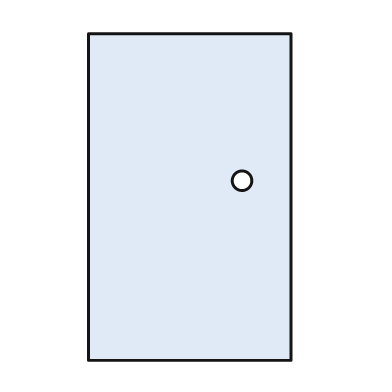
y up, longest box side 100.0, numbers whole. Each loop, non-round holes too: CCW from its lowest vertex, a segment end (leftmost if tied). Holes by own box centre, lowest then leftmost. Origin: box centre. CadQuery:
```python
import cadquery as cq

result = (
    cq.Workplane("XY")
    .moveTo(-31.0, -50.0)
    .lineTo(31.0, -50.0)
    .lineTo(31.0, 50.0)
    .lineTo(-31.0, 50.0)
    .close()
    .moveTo(16.0, 5.0)
    .circle(3.0)
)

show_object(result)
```